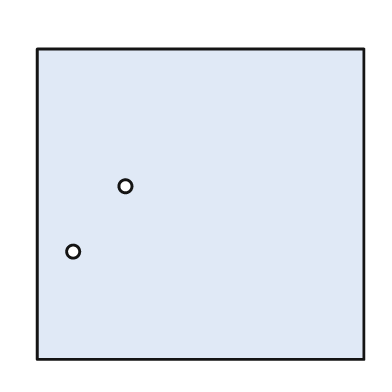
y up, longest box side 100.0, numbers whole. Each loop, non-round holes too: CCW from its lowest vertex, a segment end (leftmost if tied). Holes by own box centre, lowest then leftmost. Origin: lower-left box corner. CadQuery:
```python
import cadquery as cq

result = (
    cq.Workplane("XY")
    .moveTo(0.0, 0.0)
    .lineTo(100.0, 0.0)
    .lineTo(100.0, 95.0)
    .lineTo(0.0, 95.0)
    .close()
    .moveTo(11.0, 33.0)
    .circle(2.0)
    .moveTo(27.0, 53.0)
    .circle(2.0)
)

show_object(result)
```